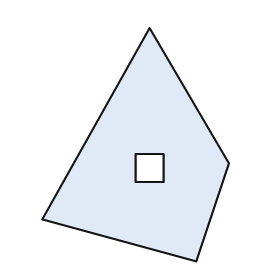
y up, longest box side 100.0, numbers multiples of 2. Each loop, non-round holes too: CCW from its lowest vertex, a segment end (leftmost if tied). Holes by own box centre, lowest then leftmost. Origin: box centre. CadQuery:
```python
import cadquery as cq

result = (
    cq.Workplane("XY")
    .moveTo(26.0, -50.0)
    .lineTo(40.0, -8.0)
    .lineTo(6.0, 50.0)
    .lineTo(-40.0, -32.0)
    .close()
    .moveTo(0.0, -16.0)
    .lineTo(12.0, -16.0)
    .lineTo(12.0, -4.0)
    .lineTo(0.0, -4.0)
    .close()
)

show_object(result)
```